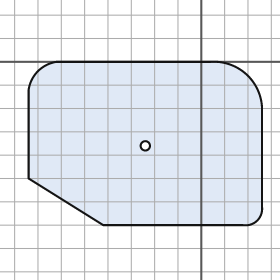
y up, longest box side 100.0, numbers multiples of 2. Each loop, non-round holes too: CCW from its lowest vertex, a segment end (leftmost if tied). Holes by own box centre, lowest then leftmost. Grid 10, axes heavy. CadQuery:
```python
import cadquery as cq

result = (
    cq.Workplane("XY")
    .moveTo(-42.0, -70.0)
    .lineTo(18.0, -70.0)
    .threePointArc((24.0, -68.0), (26.0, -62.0))
    .lineTo(26.0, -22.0)
    .threePointArc((20.0, -6.0), (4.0, 0.0))
    .lineTo(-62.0, 0.0)
    .threePointArc((-70.0, -4.0), (-74.0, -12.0))
    .lineTo(-74.0, -50.0)
    .close()
    .moveTo(-24.0, -36.0)
    .circle(2.0)
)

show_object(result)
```